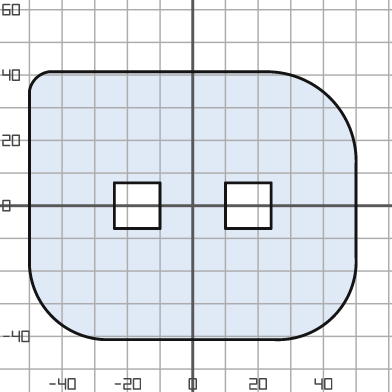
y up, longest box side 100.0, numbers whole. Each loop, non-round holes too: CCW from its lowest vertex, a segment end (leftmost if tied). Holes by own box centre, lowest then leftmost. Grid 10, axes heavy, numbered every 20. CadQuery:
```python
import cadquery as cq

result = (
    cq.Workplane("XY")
    .moveTo(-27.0, -41.0)
    .lineTo(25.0, -41.0)
    .threePointArc((43.0, -34.0), (50.0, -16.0))
    .lineTo(50.0, 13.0)
    .threePointArc((42.0, 33.0), (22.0, 41.0))
    .lineTo(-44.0, 41.0)
    .threePointArc((-48.0, 39.0), (-50.0, 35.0))
    .lineTo(-50.0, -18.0)
    .threePointArc((-43.0, -34.0), (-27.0, -41.0))
    .close()
    .moveTo(-24.0, -7.0)
    .lineTo(-10.0, -7.0)
    .lineTo(-10.0, 7.0)
    .lineTo(-24.0, 7.0)
    .close()
    .moveTo(10.0, -7.0)
    .lineTo(24.0, -7.0)
    .lineTo(24.0, 7.0)
    .lineTo(10.0, 7.0)
    .close()
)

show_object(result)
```